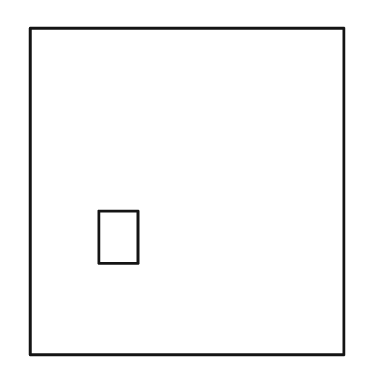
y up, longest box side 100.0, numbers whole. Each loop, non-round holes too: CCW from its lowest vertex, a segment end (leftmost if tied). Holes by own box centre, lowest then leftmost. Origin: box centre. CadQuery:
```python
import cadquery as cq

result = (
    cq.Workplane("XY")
    .moveTo(-48.0, -50.0)
    .lineTo(48.0, -50.0)
    .lineTo(48.0, 50.0)
    .lineTo(-48.0, 50.0)
    .close()
    .moveTo(-27.0, -22.0)
    .lineTo(-15.0, -22.0)
    .lineTo(-15.0, -6.0)
    .lineTo(-27.0, -6.0)
    .close()
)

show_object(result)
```